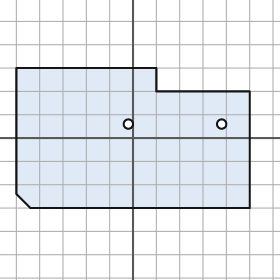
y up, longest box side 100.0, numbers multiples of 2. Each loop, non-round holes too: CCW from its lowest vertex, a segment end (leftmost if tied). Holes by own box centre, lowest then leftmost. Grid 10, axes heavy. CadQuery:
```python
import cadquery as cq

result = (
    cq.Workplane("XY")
    .moveTo(-44.0, -30.0)
    .lineTo(50.0, -30.0)
    .lineTo(50.0, 20.0)
    .lineTo(10.0, 20.0)
    .lineTo(10.0, 30.0)
    .lineTo(-50.0, 30.0)
    .lineTo(-50.0, -24.0)
    .close()
    .moveTo(-2.0, 6.0)
    .circle(2.0)
    .moveTo(38.0, 6.0)
    .circle(2.0)
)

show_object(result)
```